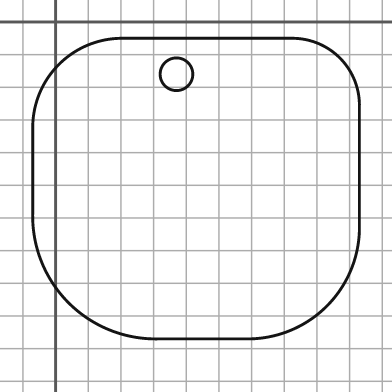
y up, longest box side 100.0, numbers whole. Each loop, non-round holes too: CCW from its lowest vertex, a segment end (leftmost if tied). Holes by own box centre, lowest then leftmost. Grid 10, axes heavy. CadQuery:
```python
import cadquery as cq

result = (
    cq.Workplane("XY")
    .moveTo(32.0, -97.0)
    .lineTo(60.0, -97.0)
    .threePointArc((83.0, -87.0), (93.0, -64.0))
    .lineTo(93.0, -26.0)
    .threePointArc((87.0, -11.0), (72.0, -5.0))
    .lineTo(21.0, -5.0)
    .threePointArc((1.0, -13.0), (-7.0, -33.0))
    .lineTo(-7.0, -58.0)
    .threePointArc((4.0, -86.0), (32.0, -97.0))
    .close()
    .moveTo(37.0, -16.0)
    .circle(5.0)
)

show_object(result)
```